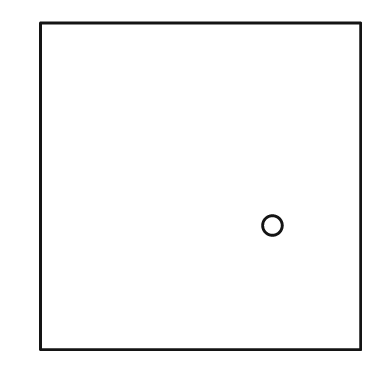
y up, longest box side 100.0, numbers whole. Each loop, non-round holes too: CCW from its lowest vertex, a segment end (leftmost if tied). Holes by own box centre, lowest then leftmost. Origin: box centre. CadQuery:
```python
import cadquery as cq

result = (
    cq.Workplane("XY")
    .moveTo(-49.0, -50.0)
    .lineTo(49.0, -50.0)
    .lineTo(49.0, 50.0)
    .lineTo(-49.0, 50.0)
    .close()
    .moveTo(22.0, -12.0)
    .circle(3.0)
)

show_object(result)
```